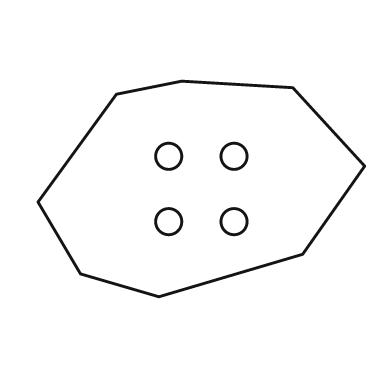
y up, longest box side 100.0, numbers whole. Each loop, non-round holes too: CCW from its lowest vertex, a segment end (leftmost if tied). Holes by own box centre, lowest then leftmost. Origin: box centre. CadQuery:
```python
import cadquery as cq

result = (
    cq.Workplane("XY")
    .moveTo(-13.0, -33.0)
    .lineTo(31.0, -20.0)
    .lineTo(50.0, 7.0)
    .lineTo(28.0, 31.0)
    .lineTo(-6.0, 33.0)
    .lineTo(-26.0, 29.0)
    .lineTo(-50.0, -4.0)
    .lineTo(-37.0, -26.0)
    .close()
    .moveTo(-10.0, -10.0)
    .circle(4.0)
    .moveTo(10.0, -10.0)
    .circle(4.0)
    .moveTo(-10.0, 10.0)
    .circle(4.0)
    .moveTo(10.0, 10.0)
    .circle(4.0)
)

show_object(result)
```